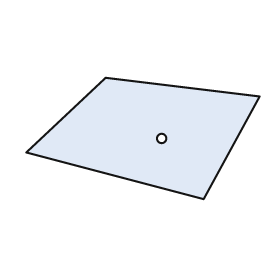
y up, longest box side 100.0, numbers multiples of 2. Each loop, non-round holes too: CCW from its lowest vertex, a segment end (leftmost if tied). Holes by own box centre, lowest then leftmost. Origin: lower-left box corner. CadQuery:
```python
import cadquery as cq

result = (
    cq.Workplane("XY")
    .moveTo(76.0, 0.0)
    .lineTo(100.0, 44.0)
    .lineTo(34.0, 52.0)
    .lineTo(0.0, 20.0)
    .close()
    .moveTo(58.0, 26.0)
    .circle(2.0)
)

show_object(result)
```